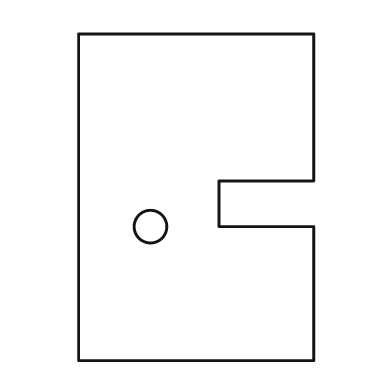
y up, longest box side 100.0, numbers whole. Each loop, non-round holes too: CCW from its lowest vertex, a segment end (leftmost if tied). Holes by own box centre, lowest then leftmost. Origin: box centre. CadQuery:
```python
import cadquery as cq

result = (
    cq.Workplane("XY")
    .moveTo(-36.0, -50.0)
    .lineTo(36.0, -50.0)
    .lineTo(36.0, -9.0)
    .lineTo(7.0, -9.0)
    .lineTo(7.0, 5.0)
    .lineTo(36.0, 5.0)
    .lineTo(36.0, 50.0)
    .lineTo(-36.0, 50.0)
    .close()
    .moveTo(-14.0, -9.0)
    .circle(5.0)
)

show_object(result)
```